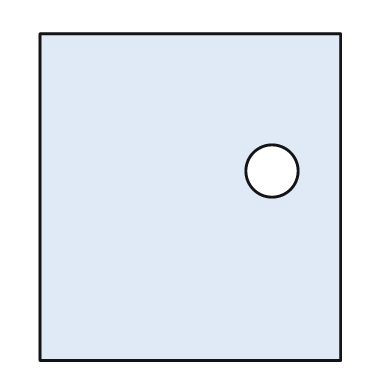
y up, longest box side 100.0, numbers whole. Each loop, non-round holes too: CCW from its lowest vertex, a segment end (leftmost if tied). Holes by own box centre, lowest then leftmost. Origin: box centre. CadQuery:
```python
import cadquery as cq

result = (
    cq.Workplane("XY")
    .moveTo(-46.0, -50.0)
    .lineTo(46.0, -50.0)
    .lineTo(46.0, 50.0)
    .lineTo(-46.0, 50.0)
    .close()
    .moveTo(25.0, 8.0)
    .circle(8.0)
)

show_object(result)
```